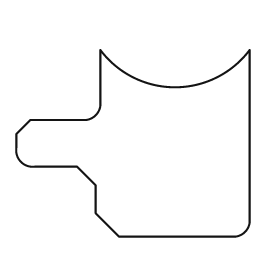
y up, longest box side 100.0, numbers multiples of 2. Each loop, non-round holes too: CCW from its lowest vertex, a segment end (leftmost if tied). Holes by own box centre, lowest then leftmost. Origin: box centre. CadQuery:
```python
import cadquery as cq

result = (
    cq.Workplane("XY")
    .moveTo(-6.0, -40.0)
    .lineTo(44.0, -40.0)
    .threePointArc((48.0, -38.0), (50.0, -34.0))
    .lineTo(50.0, 40.0)
    .threePointArc((18.0, 24.0), (-14.0, 40.0))
    .lineTo(-14.0, 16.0)
    .threePointArc((-16.0, 12.0), (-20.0, 10.0))
    .lineTo(-44.0, 10.0)
    .lineTo(-50.0, 4.0)
    .lineTo(-50.0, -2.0)
    .threePointArc((-48.0, -8.0), (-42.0, -10.0))
    .lineTo(-24.0, -10.0)
    .lineTo(-16.0, -18.0)
    .lineTo(-16.0, -30.0)
    .close()
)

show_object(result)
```